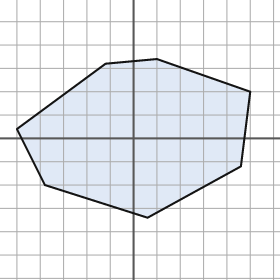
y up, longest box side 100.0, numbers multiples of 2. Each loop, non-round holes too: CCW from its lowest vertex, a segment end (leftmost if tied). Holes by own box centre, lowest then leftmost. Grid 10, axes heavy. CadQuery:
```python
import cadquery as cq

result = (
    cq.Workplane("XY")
    .moveTo(6.0, -34.0)
    .lineTo(46.0, -12.0)
    .lineTo(50.0, 20.0)
    .lineTo(10.0, 34.0)
    .lineTo(-12.0, 32.0)
    .lineTo(-50.0, 4.0)
    .lineTo(-38.0, -20.0)
    .close()
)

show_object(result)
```